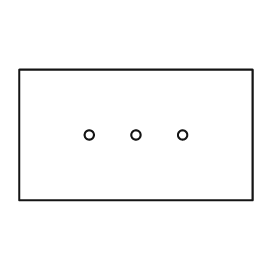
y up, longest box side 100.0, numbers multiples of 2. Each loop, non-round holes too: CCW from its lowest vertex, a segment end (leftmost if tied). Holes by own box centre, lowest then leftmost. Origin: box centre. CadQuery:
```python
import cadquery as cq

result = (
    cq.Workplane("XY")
    .moveTo(-50.0, -28.0)
    .lineTo(50.0, -28.0)
    .lineTo(50.0, 28.0)
    .lineTo(-50.0, 28.0)
    .close()
    .moveTo(-20.0, 0.0)
    .circle(2.0)
    .moveTo(0.0, 0.0)
    .circle(2.0)
    .moveTo(20.0, 0.0)
    .circle(2.0)
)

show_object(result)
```